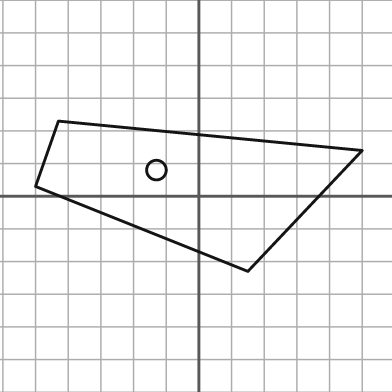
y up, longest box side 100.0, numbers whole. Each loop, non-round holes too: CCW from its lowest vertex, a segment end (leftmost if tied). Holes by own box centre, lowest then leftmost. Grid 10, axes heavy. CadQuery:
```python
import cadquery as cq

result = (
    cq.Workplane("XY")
    .moveTo(15.0, -23.0)
    .lineTo(50.0, 14.0)
    .lineTo(-43.0, 23.0)
    .lineTo(-50.0, 3.0)
    .close()
    .moveTo(-13.0, 8.0)
    .circle(3.0)
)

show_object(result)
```